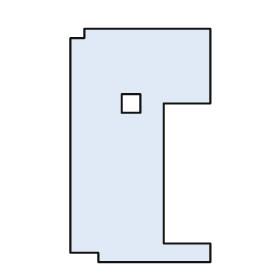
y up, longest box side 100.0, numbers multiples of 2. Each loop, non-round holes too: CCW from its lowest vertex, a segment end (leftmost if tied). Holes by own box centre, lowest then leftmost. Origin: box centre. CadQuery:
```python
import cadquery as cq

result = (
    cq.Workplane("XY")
    .moveTo(-18.0, -50.0)
    .lineTo(30.0, -50.0)
    .lineTo(30.0, -42.0)
    .lineTo(10.0, -42.0)
    .lineTo(10.0, 18.0)
    .lineTo(30.0, 18.0)
    .lineTo(30.0, 50.0)
    .lineTo(-24.0, 50.0)
    .lineTo(-24.0, 46.0)
    .lineTo(-30.0, 46.0)
    .lineTo(-30.0, -46.0)
    .lineTo(-18.0, -46.0)
    .close()
    .moveTo(-8.0, 14.0)
    .lineTo(0.0, 14.0)
    .lineTo(0.0, 22.0)
    .lineTo(-8.0, 22.0)
    .close()
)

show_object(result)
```